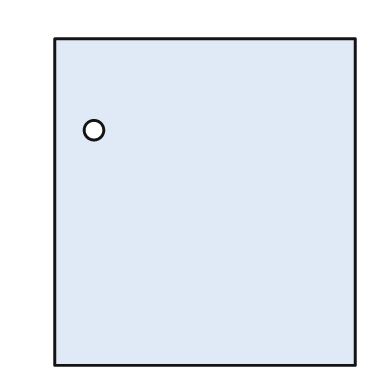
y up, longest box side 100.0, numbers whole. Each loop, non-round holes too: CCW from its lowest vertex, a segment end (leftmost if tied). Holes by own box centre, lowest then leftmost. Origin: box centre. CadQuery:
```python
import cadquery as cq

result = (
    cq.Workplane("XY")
    .moveTo(-46.0, -50.0)
    .lineTo(46.0, -50.0)
    .lineTo(46.0, 50.0)
    .lineTo(-46.0, 50.0)
    .close()
    .moveTo(-34.0, 22.0)
    .circle(3.0)
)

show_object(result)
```